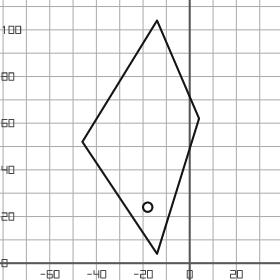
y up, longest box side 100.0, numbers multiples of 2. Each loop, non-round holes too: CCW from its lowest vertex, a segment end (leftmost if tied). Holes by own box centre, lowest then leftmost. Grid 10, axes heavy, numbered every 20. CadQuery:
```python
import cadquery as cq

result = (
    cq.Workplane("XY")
    .moveTo(-14.0, 4.0)
    .lineTo(4.0, 62.0)
    .lineTo(-14.0, 104.0)
    .lineTo(-46.0, 52.0)
    .close()
    .moveTo(-18.0, 24.0)
    .circle(2.0)
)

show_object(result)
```